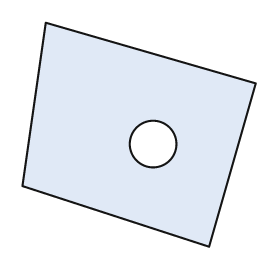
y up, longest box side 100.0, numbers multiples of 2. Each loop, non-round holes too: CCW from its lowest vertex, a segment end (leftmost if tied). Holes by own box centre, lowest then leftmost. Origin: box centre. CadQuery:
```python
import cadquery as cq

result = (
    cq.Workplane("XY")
    .moveTo(30.0, -48.0)
    .lineTo(50.0, 22.0)
    .lineTo(-40.0, 48.0)
    .lineTo(-50.0, -22.0)
    .close()
    .moveTo(6.0, -4.0)
    .circle(10.0)
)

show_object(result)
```